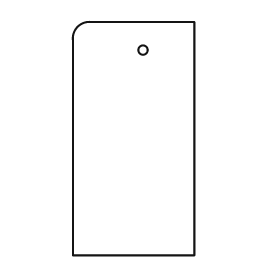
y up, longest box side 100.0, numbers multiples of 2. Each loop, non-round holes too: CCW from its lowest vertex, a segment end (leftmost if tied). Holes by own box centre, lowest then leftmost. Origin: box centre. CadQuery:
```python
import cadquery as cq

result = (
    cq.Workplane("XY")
    .moveTo(-26.0, -50.0)
    .lineTo(26.0, -50.0)
    .lineTo(26.0, 50.0)
    .lineTo(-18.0, 50.0)
    .threePointArc((-24.0, 48.0), (-26.0, 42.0))
    .close()
    .moveTo(4.0, 38.0)
    .circle(2.0)
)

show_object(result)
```